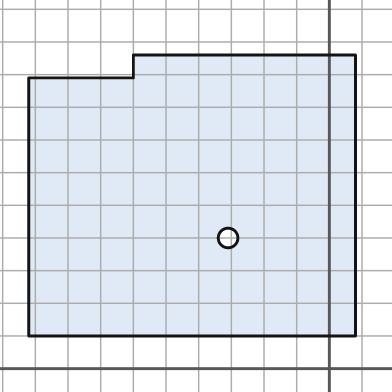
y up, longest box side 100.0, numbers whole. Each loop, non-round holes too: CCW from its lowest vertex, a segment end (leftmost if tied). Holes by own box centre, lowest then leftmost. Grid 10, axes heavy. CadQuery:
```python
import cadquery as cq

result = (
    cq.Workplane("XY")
    .moveTo(-92.0, 10.0)
    .lineTo(8.0, 10.0)
    .lineTo(8.0, 96.0)
    .lineTo(-60.0, 96.0)
    .lineTo(-60.0, 89.0)
    .lineTo(-92.0, 89.0)
    .close()
    .moveTo(-31.0, 40.0)
    .circle(3.0)
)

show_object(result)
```